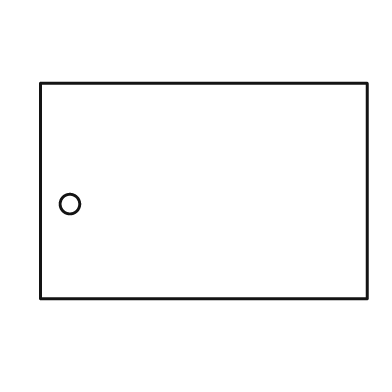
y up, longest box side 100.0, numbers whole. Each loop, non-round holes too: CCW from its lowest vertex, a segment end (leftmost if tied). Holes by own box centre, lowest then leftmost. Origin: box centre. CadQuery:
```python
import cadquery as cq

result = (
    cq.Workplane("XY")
    .moveTo(-50.0, -33.0)
    .lineTo(50.0, -33.0)
    .lineTo(50.0, 33.0)
    .lineTo(-50.0, 33.0)
    .close()
    .moveTo(-41.0, -4.0)
    .circle(3.0)
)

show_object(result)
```